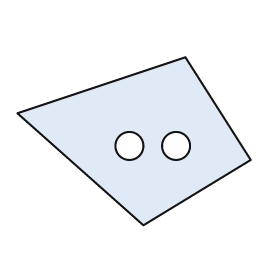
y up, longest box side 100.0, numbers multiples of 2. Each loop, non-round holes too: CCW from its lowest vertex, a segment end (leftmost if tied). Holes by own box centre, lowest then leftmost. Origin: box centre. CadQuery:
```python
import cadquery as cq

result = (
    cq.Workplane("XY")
    .moveTo(4.0, -36.0)
    .lineTo(50.0, -8.0)
    .lineTo(22.0, 36.0)
    .lineTo(-50.0, 12.0)
    .close()
    .moveTo(-2.0, -2.0)
    .circle(6.0)
    .moveTo(18.0, -2.0)
    .circle(6.0)
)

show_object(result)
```